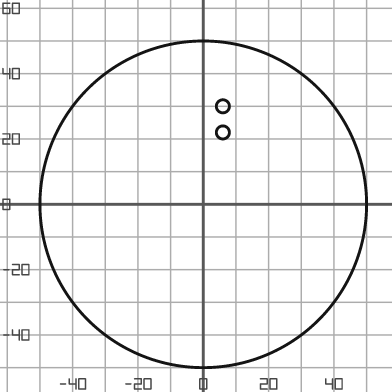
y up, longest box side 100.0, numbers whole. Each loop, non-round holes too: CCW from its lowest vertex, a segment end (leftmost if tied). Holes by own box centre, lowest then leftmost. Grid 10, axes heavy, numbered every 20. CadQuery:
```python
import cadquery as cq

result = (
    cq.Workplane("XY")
    .moveTo(0.0, 0.0)
    .circle(50.0)
    .moveTo(6.0, 22.0)
    .circle(2.0)
    .moveTo(6.0, 30.0)
    .circle(2.0)
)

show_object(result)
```